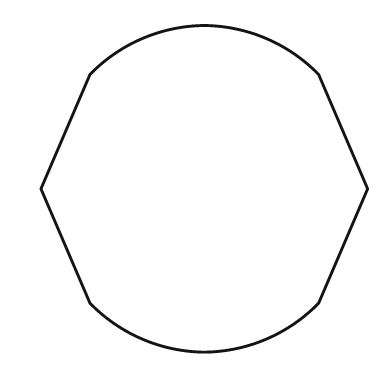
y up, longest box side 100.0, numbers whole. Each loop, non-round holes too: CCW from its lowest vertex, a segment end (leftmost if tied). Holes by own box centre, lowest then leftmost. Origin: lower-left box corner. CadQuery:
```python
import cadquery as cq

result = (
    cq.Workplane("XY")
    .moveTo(50.0, 0.0)
    .threePointArc((69.0, 4.0), (85.0, 15.0))
    .lineTo(100.0, 50.0)
    .lineTo(85.0, 85.0)
    .threePointArc((69.0, 96.0), (50.0, 100.0))
    .threePointArc((31.0, 96.0), (15.0, 85.0))
    .lineTo(0.0, 50.0)
    .lineTo(15.0, 15.0)
    .threePointArc((31.0, 4.0), (50.0, 0.0))
    .close()
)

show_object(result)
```